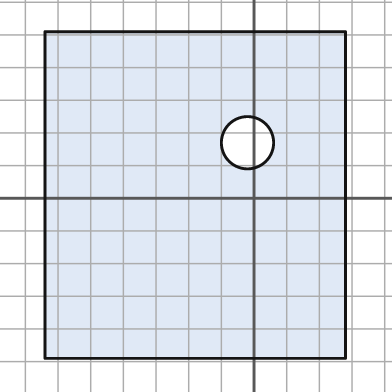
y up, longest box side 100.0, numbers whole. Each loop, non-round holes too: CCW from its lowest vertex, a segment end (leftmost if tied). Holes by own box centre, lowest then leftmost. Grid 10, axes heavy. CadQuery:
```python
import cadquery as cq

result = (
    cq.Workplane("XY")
    .moveTo(-64.0, -49.0)
    .lineTo(28.0, -49.0)
    .lineTo(28.0, 51.0)
    .lineTo(-64.0, 51.0)
    .close()
    .moveTo(-2.0, 17.0)
    .circle(8.0)
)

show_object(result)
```